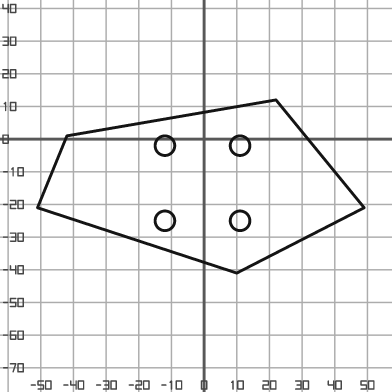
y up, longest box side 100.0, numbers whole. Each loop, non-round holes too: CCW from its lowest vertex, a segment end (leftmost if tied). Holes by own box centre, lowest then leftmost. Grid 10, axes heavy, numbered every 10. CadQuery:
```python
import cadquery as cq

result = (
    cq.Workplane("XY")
    .moveTo(10.0, -41.0)
    .lineTo(49.0, -21.0)
    .lineTo(22.0, 12.0)
    .lineTo(-42.0, 1.0)
    .lineTo(-51.0, -21.0)
    .close()
    .moveTo(-12.0, -25.0)
    .circle(3.0)
    .moveTo(11.0, -25.0)
    .circle(3.0)
    .moveTo(-12.0, -2.0)
    .circle(3.0)
    .moveTo(11.0, -2.0)
    .circle(3.0)
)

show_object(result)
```